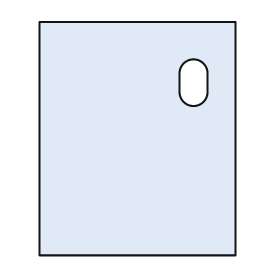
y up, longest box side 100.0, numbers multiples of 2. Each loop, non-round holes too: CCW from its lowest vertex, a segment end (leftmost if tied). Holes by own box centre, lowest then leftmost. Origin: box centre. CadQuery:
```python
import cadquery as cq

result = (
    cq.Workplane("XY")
    .moveTo(-42.0, -50.0)
    .lineTo(42.0, -50.0)
    .lineTo(42.0, 50.0)
    .lineTo(-42.0, 50.0)
    .close()
    .moveTo(18.0, 20.0)
    .threePointArc((24.0, 14.0), (30.0, 20.0))
    .lineTo(30.0, 28.0)
    .threePointArc((24.0, 34.0), (18.0, 28.0))
    .close()
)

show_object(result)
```